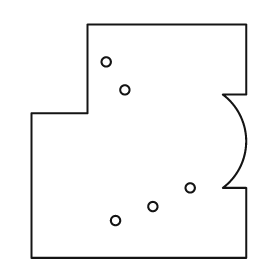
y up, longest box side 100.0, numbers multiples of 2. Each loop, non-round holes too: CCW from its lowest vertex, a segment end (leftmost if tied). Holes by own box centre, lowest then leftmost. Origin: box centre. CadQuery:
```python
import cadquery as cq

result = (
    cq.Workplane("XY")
    .moveTo(-46.0, -50.0)
    .lineTo(46.0, -50.0)
    .lineTo(46.0, -20.0)
    .lineTo(36.0, -20.0)
    .threePointArc((46.0, 0.0), (36.0, 20.0))
    .lineTo(46.0, 20.0)
    .lineTo(46.0, 50.0)
    .lineTo(-22.0, 50.0)
    .lineTo(-22.0, 12.0)
    .lineTo(-46.0, 12.0)
    .close()
    .moveTo(-10.0, -34.0)
    .circle(2.0)
    .moveTo(6.0, -28.0)
    .circle(2.0)
    .moveTo(22.0, -20.0)
    .circle(2.0)
    .moveTo(-6.0, 22.0)
    .circle(2.0)
    .moveTo(-14.0, 34.0)
    .circle(2.0)
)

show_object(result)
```